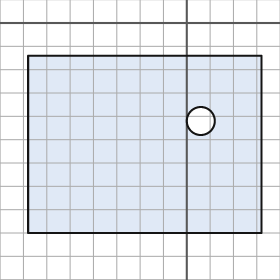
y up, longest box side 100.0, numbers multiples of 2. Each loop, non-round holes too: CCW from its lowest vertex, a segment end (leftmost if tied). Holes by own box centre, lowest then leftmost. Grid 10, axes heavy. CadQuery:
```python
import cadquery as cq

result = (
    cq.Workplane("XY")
    .moveTo(-68.0, -90.0)
    .lineTo(32.0, -90.0)
    .lineTo(32.0, -14.0)
    .lineTo(-68.0, -14.0)
    .close()
    .moveTo(6.0, -42.0)
    .circle(6.0)
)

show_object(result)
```